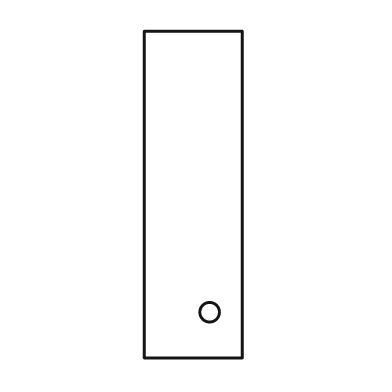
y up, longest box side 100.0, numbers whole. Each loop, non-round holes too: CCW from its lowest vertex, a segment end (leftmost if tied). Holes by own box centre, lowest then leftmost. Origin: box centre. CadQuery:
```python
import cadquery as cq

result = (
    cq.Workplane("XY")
    .moveTo(-15.0, -50.0)
    .lineTo(15.0, -50.0)
    .lineTo(15.0, 50.0)
    .lineTo(-15.0, 50.0)
    .close()
    .moveTo(5.0, -36.0)
    .circle(3.0)
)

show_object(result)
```